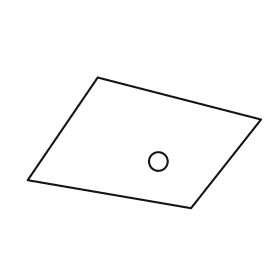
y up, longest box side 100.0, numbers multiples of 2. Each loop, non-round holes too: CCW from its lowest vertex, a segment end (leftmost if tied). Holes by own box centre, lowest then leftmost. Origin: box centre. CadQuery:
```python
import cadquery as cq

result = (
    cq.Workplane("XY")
    .moveTo(20.0, -28.0)
    .lineTo(50.0, 10.0)
    .lineTo(-20.0, 28.0)
    .lineTo(-50.0, -16.0)
    .close()
    .moveTo(6.0, -8.0)
    .circle(4.0)
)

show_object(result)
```